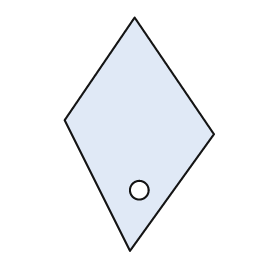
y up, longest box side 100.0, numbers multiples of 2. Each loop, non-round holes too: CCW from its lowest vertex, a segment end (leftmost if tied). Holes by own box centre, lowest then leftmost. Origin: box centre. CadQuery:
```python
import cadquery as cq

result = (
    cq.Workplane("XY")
    .moveTo(-4.0, -50.0)
    .lineTo(32.0, 0.0)
    .lineTo(-2.0, 50.0)
    .lineTo(-32.0, 6.0)
    .close()
    .moveTo(0.0, -24.0)
    .circle(4.0)
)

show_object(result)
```